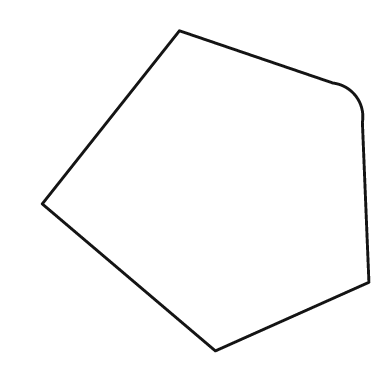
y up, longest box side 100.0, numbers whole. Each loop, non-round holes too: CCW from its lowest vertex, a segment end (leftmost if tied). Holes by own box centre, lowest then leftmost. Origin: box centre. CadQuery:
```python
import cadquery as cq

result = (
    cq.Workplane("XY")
    .moveTo(3.0, -49.0)
    .lineTo(50.0, -28.0)
    .lineTo(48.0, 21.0)
    .threePointArc((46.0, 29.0), (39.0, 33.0))
    .lineTo(-8.0, 49.0)
    .lineTo(-50.0, -4.0)
    .close()
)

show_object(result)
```